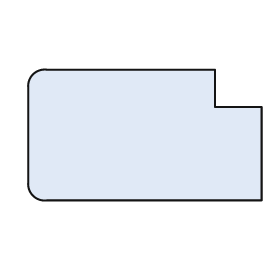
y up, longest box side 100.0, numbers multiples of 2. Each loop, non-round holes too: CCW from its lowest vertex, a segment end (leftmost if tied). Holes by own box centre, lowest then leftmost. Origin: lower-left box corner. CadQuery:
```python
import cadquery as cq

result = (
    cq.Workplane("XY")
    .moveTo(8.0, 0.0)
    .lineTo(100.0, 0.0)
    .lineTo(100.0, 40.0)
    .lineTo(80.0, 40.0)
    .lineTo(80.0, 56.0)
    .lineTo(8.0, 56.0)
    .threePointArc((2.0, 54.0), (0.0, 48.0))
    .lineTo(0.0, 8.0)
    .threePointArc((2.0, 2.0), (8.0, 0.0))
    .close()
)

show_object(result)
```